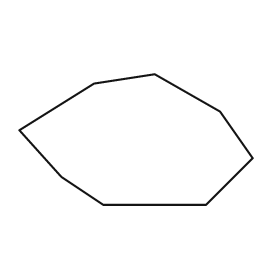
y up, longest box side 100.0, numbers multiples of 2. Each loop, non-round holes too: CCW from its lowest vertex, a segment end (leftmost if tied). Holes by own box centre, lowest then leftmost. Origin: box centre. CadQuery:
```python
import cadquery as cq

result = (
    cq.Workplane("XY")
    .moveTo(-14.0, -28.0)
    .lineTo(30.0, -28.0)
    .lineTo(50.0, -8.0)
    .lineTo(36.0, 12.0)
    .lineTo(8.0, 28.0)
    .lineTo(-18.0, 24.0)
    .lineTo(-50.0, 4.0)
    .lineTo(-32.0, -16.0)
    .close()
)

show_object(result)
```